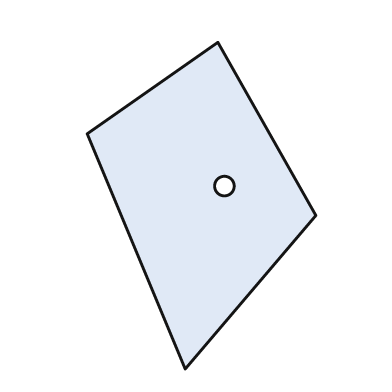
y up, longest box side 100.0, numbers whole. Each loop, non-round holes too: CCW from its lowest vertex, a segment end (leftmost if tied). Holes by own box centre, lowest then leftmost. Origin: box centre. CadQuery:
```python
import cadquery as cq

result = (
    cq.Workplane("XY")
    .moveTo(-5.0, -50.0)
    .lineTo(35.0, -3.0)
    .lineTo(5.0, 50.0)
    .lineTo(-35.0, 22.0)
    .close()
    .moveTo(7.0, 6.0)
    .circle(3.0)
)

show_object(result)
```